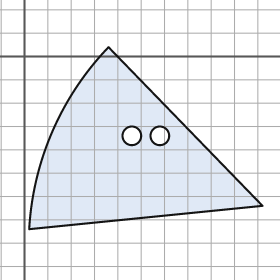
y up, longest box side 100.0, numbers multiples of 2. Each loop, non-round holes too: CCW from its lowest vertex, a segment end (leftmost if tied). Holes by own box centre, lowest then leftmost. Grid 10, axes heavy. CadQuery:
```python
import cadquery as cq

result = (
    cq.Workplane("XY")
    .moveTo(2.0, -74.0)
    .lineTo(102.0, -64.0)
    .lineTo(36.0, 4.0)
    .threePointArc((12.0, -32.0), (2.0, -74.0))
    .close()
    .moveTo(46.0, -34.0)
    .circle(4.0)
    .moveTo(58.0, -34.0)
    .circle(4.0)
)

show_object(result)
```